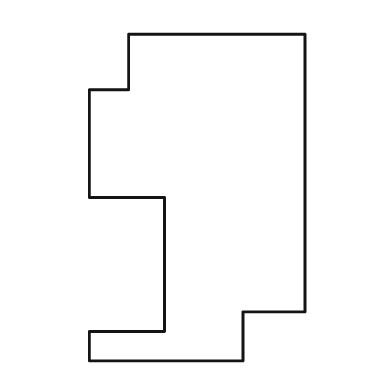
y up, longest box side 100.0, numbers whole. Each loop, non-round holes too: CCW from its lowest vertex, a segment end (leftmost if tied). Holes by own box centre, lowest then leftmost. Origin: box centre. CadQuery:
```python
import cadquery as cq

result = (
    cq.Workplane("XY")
    .moveTo(-33.0, -50.0)
    .lineTo(14.0, -50.0)
    .lineTo(14.0, -35.0)
    .lineTo(33.0, -35.0)
    .lineTo(33.0, 50.0)
    .lineTo(-21.0, 50.0)
    .lineTo(-21.0, 33.0)
    .lineTo(-33.0, 33.0)
    .lineTo(-33.0, 0.0)
    .lineTo(-10.0, 0.0)
    .lineTo(-10.0, -41.0)
    .lineTo(-33.0, -41.0)
    .close()
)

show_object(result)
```